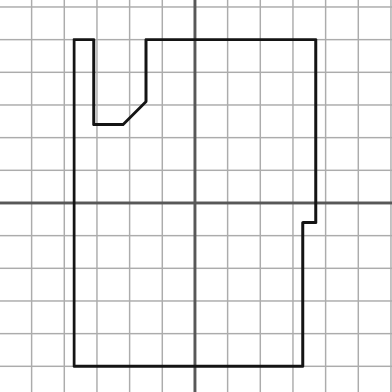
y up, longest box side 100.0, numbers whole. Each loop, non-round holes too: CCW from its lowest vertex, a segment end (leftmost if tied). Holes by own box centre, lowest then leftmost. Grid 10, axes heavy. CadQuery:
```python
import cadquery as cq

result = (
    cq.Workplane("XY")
    .moveTo(-37.0, -50.0)
    .lineTo(33.0, -50.0)
    .lineTo(33.0, -6.0)
    .lineTo(37.0, -6.0)
    .lineTo(37.0, 50.0)
    .lineTo(-15.0, 50.0)
    .lineTo(-15.0, 31.0)
    .lineTo(-22.0, 24.0)
    .lineTo(-31.0, 24.0)
    .lineTo(-31.0, 50.0)
    .lineTo(-37.0, 50.0)
    .close()
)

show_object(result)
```